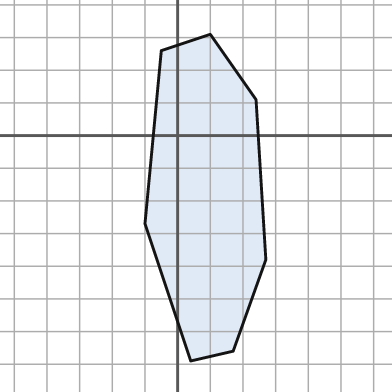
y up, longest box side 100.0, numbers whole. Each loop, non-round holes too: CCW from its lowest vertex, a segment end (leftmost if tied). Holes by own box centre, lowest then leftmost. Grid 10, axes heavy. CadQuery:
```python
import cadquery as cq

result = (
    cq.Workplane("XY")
    .moveTo(4.0, -69.0)
    .lineTo(17.0, -66.0)
    .lineTo(27.0, -38.0)
    .lineTo(24.0, 11.0)
    .lineTo(10.0, 31.0)
    .lineTo(-5.0, 26.0)
    .lineTo(-10.0, -27.0)
    .close()
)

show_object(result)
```